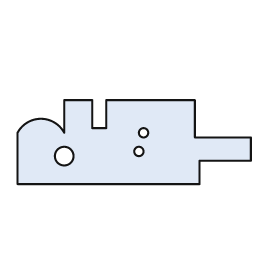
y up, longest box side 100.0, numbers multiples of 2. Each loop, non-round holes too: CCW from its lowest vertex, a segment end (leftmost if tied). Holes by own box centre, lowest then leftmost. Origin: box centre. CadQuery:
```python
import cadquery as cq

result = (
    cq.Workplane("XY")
    .moveTo(-50.0, -18.0)
    .lineTo(28.0, -18.0)
    .lineTo(28.0, -8.0)
    .lineTo(50.0, -8.0)
    .lineTo(50.0, 2.0)
    .lineTo(26.0, 2.0)
    .lineTo(26.0, 18.0)
    .lineTo(-12.0, 18.0)
    .lineTo(-12.0, 6.0)
    .lineTo(-18.0, 6.0)
    .lineTo(-18.0, 18.0)
    .lineTo(-30.0, 18.0)
    .lineTo(-30.0, 4.0)
    .threePointArc((-40.0, 10.0), (-50.0, 4.0))
    .close()
    .moveTo(-30.0, -6.0)
    .circle(4.0)
    .moveTo(2.0, -4.0)
    .circle(2.0)
    .moveTo(4.0, 4.0)
    .circle(2.0)
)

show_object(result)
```